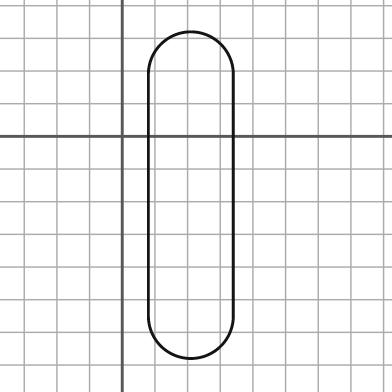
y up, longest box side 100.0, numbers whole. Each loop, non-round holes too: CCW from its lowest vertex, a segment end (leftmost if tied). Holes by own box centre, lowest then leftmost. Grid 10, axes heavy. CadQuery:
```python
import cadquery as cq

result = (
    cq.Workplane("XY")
    .moveTo(8.0, -55.0)
    .threePointArc((21.0, -68.0), (34.0, -55.0))
    .lineTo(34.0, 19.0)
    .threePointArc((21.0, 32.0), (8.0, 19.0))
    .close()
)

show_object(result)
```